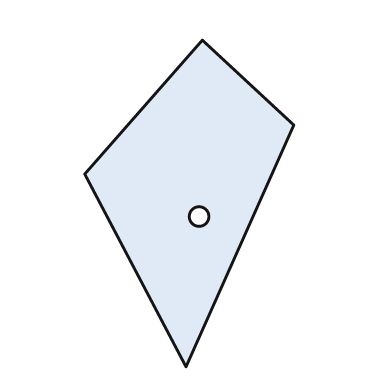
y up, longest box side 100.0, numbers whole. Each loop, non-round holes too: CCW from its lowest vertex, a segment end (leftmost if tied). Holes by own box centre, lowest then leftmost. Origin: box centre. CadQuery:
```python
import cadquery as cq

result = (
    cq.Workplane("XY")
    .moveTo(-1.0, -50.0)
    .lineTo(32.0, 24.0)
    .lineTo(4.0, 50.0)
    .lineTo(-32.0, 9.0)
    .close()
    .moveTo(3.0, -4.0)
    .circle(3.0)
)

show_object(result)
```